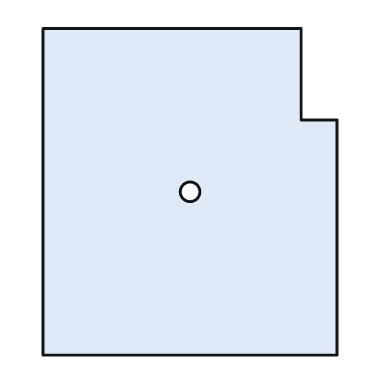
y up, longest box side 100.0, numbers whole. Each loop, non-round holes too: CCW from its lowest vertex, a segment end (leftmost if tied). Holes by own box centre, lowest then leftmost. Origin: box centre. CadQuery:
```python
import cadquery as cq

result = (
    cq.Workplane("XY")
    .moveTo(-45.0, -50.0)
    .lineTo(45.0, -50.0)
    .lineTo(45.0, 22.0)
    .lineTo(34.0, 22.0)
    .lineTo(34.0, 50.0)
    .lineTo(-45.0, 50.0)
    .close()
    .moveTo(0.0, 0.0)
    .circle(3.0)
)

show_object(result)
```